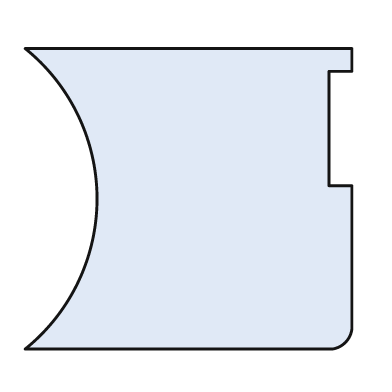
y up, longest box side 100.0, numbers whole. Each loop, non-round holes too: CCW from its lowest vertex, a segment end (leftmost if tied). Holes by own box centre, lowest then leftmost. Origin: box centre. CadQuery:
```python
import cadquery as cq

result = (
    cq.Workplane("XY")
    .moveTo(-50.0, -46.0)
    .lineTo(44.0, -46.0)
    .threePointArc((48.0, -44.0), (50.0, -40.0))
    .lineTo(50.0, 4.0)
    .lineTo(43.0, 4.0)
    .lineTo(43.0, 39.0)
    .lineTo(50.0, 39.0)
    .lineTo(50.0, 46.0)
    .lineTo(-50.0, 46.0)
    .threePointArc((-28.0, 0.0), (-50.0, -46.0))
    .close()
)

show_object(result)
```